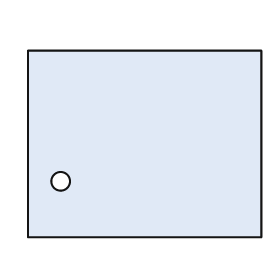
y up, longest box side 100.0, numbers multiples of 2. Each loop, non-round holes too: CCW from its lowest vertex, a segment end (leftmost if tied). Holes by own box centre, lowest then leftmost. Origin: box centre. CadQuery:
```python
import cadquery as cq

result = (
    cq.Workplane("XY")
    .moveTo(-50.0, -40.0)
    .lineTo(50.0, -40.0)
    .lineTo(50.0, 40.0)
    .lineTo(-50.0, 40.0)
    .close()
    .moveTo(-36.0, -16.0)
    .circle(4.0)
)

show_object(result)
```